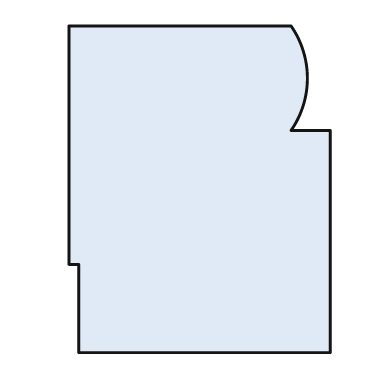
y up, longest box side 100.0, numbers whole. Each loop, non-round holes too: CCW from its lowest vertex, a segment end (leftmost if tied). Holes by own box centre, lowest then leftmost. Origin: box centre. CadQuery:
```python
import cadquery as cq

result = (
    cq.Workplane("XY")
    .moveTo(-37.0, -50.0)
    .lineTo(40.0, -50.0)
    .lineTo(40.0, 18.0)
    .lineTo(28.0, 18.0)
    .threePointArc((33.0, 34.0), (28.0, 50.0))
    .lineTo(-40.0, 50.0)
    .lineTo(-40.0, -23.0)
    .lineTo(-37.0, -23.0)
    .close()
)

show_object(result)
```